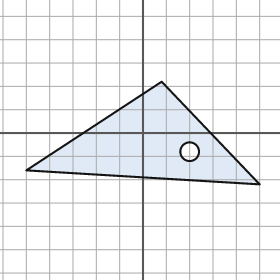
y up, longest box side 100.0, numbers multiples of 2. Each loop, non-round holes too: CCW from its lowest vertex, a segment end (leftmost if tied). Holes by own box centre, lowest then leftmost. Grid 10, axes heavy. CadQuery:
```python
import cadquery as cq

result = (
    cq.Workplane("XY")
    .moveTo(50.0, -22.0)
    .lineTo(8.0, 22.0)
    .lineTo(-50.0, -16.0)
    .close()
    .moveTo(20.0, -8.0)
    .circle(4.0)
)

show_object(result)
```